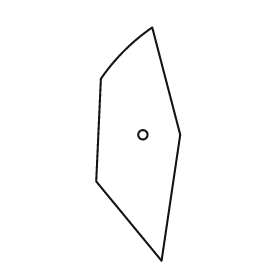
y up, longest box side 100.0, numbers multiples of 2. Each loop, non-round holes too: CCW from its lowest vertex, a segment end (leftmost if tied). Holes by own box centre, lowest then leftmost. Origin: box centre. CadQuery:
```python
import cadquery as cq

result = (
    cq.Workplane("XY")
    .moveTo(10.0, -50.0)
    .lineTo(18.0, 4.0)
    .lineTo(6.0, 50.0)
    .threePointArc((-6.0, 40.0), (-16.0, 28.0))
    .lineTo(-18.0, -16.0)
    .close()
    .moveTo(2.0, 4.0)
    .circle(2.0)
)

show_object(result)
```